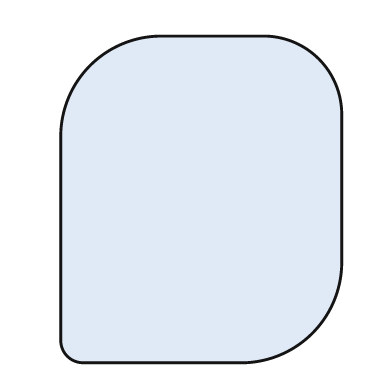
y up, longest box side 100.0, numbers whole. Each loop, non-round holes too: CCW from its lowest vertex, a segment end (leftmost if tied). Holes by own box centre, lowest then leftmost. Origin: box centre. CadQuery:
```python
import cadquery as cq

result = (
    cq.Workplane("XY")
    .moveTo(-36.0, -50.0)
    .lineTo(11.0, -50.0)
    .threePointArc((34.0, -41.0), (43.0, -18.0))
    .lineTo(43.0, 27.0)
    .threePointArc((36.0, 43.0), (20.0, 50.0))
    .lineTo(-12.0, 50.0)
    .threePointArc((-34.0, 41.0), (-43.0, 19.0))
    .lineTo(-43.0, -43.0)
    .threePointArc((-41.0, -48.0), (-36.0, -50.0))
    .close()
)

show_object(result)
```